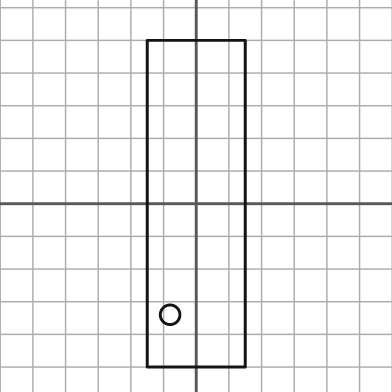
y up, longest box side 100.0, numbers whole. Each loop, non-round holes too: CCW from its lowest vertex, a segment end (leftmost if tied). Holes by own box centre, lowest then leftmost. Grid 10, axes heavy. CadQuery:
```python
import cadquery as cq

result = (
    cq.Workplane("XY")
    .moveTo(-15.0, -50.0)
    .lineTo(15.0, -50.0)
    .lineTo(15.0, 50.0)
    .lineTo(-15.0, 50.0)
    .close()
    .moveTo(-8.0, -34.0)
    .circle(3.0)
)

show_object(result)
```